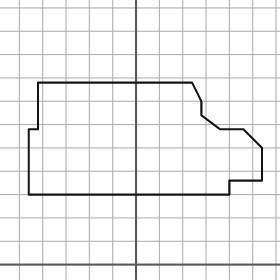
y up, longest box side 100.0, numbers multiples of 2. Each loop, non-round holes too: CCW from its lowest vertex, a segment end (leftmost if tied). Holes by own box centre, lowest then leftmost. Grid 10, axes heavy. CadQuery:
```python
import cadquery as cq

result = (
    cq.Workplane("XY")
    .moveTo(-46.0, 30.0)
    .lineTo(40.0, 30.0)
    .lineTo(40.0, 36.0)
    .lineTo(54.0, 36.0)
    .lineTo(54.0, 50.0)
    .lineTo(46.0, 58.0)
    .lineTo(36.0, 58.0)
    .lineTo(28.0, 64.0)
    .lineTo(28.0, 70.0)
    .lineTo(24.0, 78.0)
    .lineTo(-42.0, 78.0)
    .lineTo(-42.0, 58.0)
    .lineTo(-46.0, 58.0)
    .close()
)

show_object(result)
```